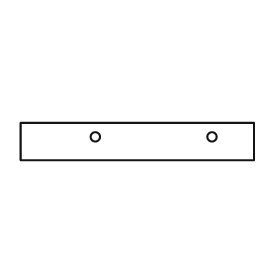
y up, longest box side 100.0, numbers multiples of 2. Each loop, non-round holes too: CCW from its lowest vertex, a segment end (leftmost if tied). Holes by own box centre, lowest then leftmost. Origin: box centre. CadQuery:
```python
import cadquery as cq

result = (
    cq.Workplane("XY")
    .moveTo(-50.0, -8.0)
    .lineTo(50.0, -8.0)
    .lineTo(50.0, 8.0)
    .lineTo(-50.0, 8.0)
    .close()
    .moveTo(-18.0, 2.0)
    .circle(2.0)
    .moveTo(32.0, 2.0)
    .circle(2.0)
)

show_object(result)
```